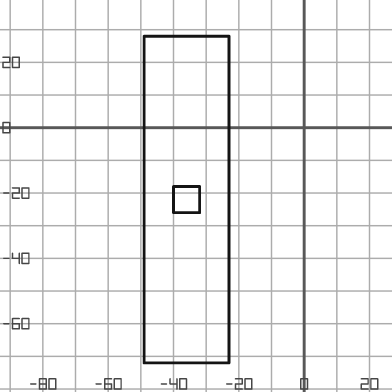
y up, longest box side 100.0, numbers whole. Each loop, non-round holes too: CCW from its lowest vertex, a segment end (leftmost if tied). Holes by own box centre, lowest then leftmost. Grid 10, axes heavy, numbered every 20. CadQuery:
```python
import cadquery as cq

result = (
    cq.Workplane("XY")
    .moveTo(-49.0, -72.0)
    .lineTo(-23.0, -72.0)
    .lineTo(-23.0, 28.0)
    .lineTo(-49.0, 28.0)
    .close()
    .moveTo(-40.0, -26.0)
    .lineTo(-32.0, -26.0)
    .lineTo(-32.0, -18.0)
    .lineTo(-40.0, -18.0)
    .close()
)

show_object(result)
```